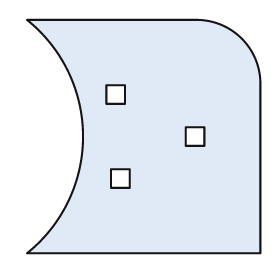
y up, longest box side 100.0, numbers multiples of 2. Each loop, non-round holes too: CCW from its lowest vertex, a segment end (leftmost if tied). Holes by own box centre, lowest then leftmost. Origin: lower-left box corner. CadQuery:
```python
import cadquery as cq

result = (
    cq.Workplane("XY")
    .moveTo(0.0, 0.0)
    .lineTo(100.0, 0.0)
    .lineTo(100.0, 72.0)
    .threePointArc((92.0, 92.0), (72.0, 100.0))
    .lineTo(0.0, 100.0)
    .threePointArc((24.0, 50.0), (0.0, 0.0))
    .close()
    .moveTo(36.0, 28.0)
    .lineTo(44.0, 28.0)
    .lineTo(44.0, 36.0)
    .lineTo(36.0, 36.0)
    .close()
    .moveTo(68.0, 46.0)
    .lineTo(76.0, 46.0)
    .lineTo(76.0, 54.0)
    .lineTo(68.0, 54.0)
    .close()
    .moveTo(34.0, 64.0)
    .lineTo(42.0, 64.0)
    .lineTo(42.0, 72.0)
    .lineTo(34.0, 72.0)
    .close()
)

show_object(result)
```